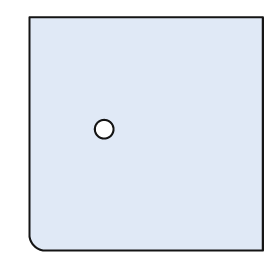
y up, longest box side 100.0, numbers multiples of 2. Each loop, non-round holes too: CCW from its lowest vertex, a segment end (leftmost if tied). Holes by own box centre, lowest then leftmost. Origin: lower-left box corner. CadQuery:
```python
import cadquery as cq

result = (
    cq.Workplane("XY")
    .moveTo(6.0, 0.0)
    .lineTo(100.0, 0.0)
    .lineTo(100.0, 100.0)
    .lineTo(0.0, 100.0)
    .lineTo(0.0, 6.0)
    .threePointArc((2.0, 2.0), (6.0, 0.0))
    .close()
    .moveTo(32.0, 52.0)
    .circle(4.0)
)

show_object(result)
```